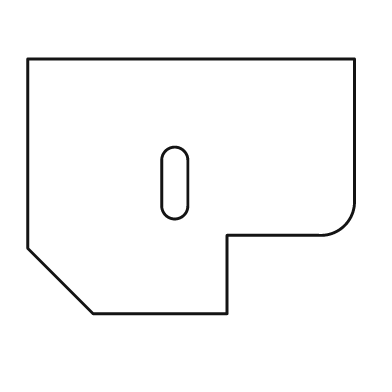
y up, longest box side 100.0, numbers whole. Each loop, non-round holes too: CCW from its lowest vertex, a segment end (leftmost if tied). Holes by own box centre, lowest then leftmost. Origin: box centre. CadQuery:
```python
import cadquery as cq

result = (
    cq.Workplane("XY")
    .moveTo(-30.0, -39.0)
    .lineTo(11.0, -39.0)
    .lineTo(11.0, -15.0)
    .lineTo(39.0, -15.0)
    .threePointArc((47.0, -12.0), (50.0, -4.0))
    .lineTo(50.0, 39.0)
    .lineTo(-50.0, 39.0)
    .lineTo(-50.0, -19.0)
    .close()
    .moveTo(-9.0, -6.0)
    .threePointArc((-5.0, -10.0), (-1.0, -6.0))
    .lineTo(-1.0, 8.0)
    .threePointArc((-5.0, 12.0), (-9.0, 8.0))
    .close()
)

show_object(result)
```